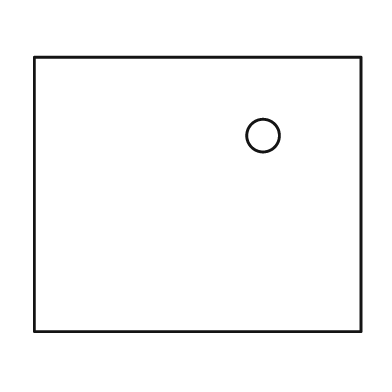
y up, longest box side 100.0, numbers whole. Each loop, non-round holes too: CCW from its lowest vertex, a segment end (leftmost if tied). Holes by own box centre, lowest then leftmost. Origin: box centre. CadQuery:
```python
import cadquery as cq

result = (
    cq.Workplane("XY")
    .moveTo(-50.0, -42.0)
    .lineTo(50.0, -42.0)
    .lineTo(50.0, 42.0)
    .lineTo(-50.0, 42.0)
    .close()
    .moveTo(20.0, 18.0)
    .circle(5.0)
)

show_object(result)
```